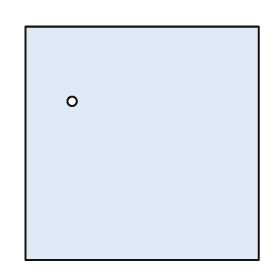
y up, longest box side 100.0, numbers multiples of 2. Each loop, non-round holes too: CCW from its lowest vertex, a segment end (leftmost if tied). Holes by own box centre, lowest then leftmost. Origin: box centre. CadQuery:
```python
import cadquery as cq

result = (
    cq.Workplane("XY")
    .moveTo(-50.0, -50.0)
    .lineTo(50.0, -50.0)
    .lineTo(50.0, 50.0)
    .lineTo(-50.0, 50.0)
    .close()
    .moveTo(-30.0, 18.0)
    .circle(2.0)
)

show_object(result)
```